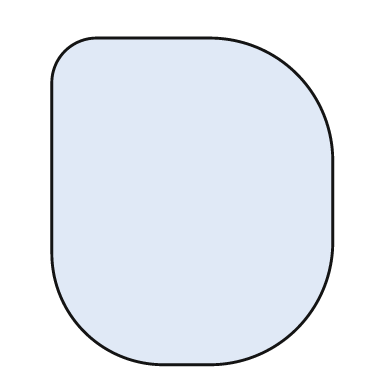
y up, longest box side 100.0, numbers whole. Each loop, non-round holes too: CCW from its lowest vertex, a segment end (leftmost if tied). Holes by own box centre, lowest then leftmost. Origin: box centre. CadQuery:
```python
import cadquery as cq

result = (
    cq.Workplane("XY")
    .moveTo(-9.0, -50.0)
    .lineTo(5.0, -50.0)
    .threePointArc((32.0, -39.0), (43.0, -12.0))
    .lineTo(43.0, 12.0)
    .threePointArc((32.0, 39.0), (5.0, 50.0))
    .lineTo(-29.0, 50.0)
    .threePointArc((-39.0, 46.0), (-43.0, 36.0))
    .lineTo(-43.0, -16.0)
    .threePointArc((-33.0, -40.0), (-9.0, -50.0))
    .close()
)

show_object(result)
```